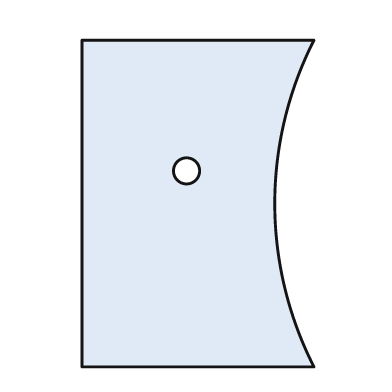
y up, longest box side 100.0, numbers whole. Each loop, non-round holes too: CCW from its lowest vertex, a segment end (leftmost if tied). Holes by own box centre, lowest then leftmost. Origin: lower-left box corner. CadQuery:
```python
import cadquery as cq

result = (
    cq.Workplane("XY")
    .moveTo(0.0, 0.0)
    .lineTo(71.0, 0.0)
    .threePointArc((59.0, 50.0), (71.0, 100.0))
    .lineTo(0.0, 100.0)
    .close()
    .moveTo(32.0, 60.0)
    .circle(4.0)
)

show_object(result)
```